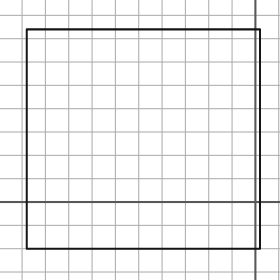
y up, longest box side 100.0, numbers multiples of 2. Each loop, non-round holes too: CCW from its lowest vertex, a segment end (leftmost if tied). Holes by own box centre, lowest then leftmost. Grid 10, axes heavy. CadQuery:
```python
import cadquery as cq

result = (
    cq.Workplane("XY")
    .moveTo(-98.0, -20.0)
    .lineTo(2.0, -20.0)
    .lineTo(2.0, 74.0)
    .lineTo(-98.0, 74.0)
    .close()
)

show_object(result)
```